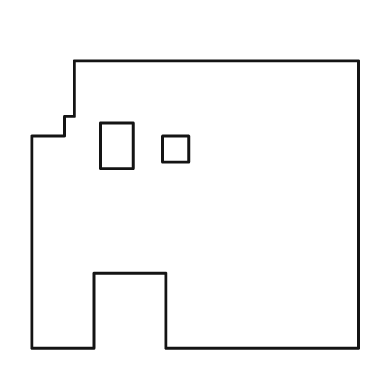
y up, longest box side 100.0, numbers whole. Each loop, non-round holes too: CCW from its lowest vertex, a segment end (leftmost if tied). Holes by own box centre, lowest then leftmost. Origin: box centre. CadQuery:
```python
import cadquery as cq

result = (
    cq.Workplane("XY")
    .moveTo(-50.0, -44.0)
    .lineTo(-31.0, -44.0)
    .lineTo(-31.0, -21.0)
    .lineTo(-9.0, -21.0)
    .lineTo(-9.0, -44.0)
    .lineTo(50.0, -44.0)
    .lineTo(50.0, 44.0)
    .lineTo(-37.0, 44.0)
    .lineTo(-37.0, 27.0)
    .lineTo(-40.0, 27.0)
    .lineTo(-40.0, 21.0)
    .lineTo(-50.0, 21.0)
    .close()
    .moveTo(-10.0, 13.0)
    .lineTo(-2.0, 13.0)
    .lineTo(-2.0, 21.0)
    .lineTo(-10.0, 21.0)
    .close()
    .moveTo(-29.0, 11.0)
    .lineTo(-19.0, 11.0)
    .lineTo(-19.0, 25.0)
    .lineTo(-29.0, 25.0)
    .close()
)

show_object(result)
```